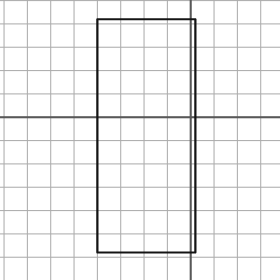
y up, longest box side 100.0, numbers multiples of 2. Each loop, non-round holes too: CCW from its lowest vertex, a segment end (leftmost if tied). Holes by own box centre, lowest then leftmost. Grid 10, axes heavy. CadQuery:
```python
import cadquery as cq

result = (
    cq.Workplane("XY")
    .moveTo(-40.0, -58.0)
    .lineTo(2.0, -58.0)
    .lineTo(2.0, 42.0)
    .lineTo(-40.0, 42.0)
    .close()
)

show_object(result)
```